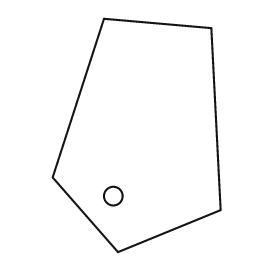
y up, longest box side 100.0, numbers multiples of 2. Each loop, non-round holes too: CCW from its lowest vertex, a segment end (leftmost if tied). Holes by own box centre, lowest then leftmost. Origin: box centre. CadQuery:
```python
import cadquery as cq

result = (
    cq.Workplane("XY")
    .moveTo(-8.0, -50.0)
    .lineTo(36.0, -32.0)
    .lineTo(32.0, 46.0)
    .lineTo(-14.0, 50.0)
    .lineTo(-36.0, -18.0)
    .close()
    .moveTo(-10.0, -26.0)
    .circle(4.0)
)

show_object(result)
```